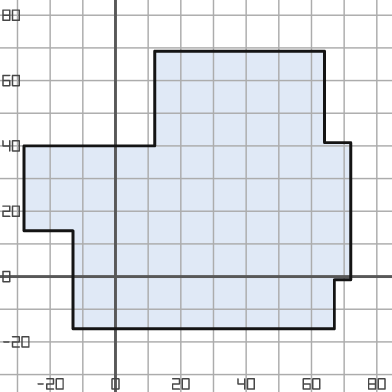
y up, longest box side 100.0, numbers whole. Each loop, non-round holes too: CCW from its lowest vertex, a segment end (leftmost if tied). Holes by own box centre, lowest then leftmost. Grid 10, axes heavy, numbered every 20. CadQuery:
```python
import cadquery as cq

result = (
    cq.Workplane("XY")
    .moveTo(-13.0, -16.0)
    .lineTo(67.0, -16.0)
    .lineTo(67.0, -1.0)
    .lineTo(72.0, -1.0)
    .lineTo(72.0, 41.0)
    .lineTo(64.0, 41.0)
    .lineTo(64.0, 69.0)
    .lineTo(12.0, 69.0)
    .lineTo(12.0, 40.0)
    .lineTo(-28.0, 40.0)
    .lineTo(-28.0, 14.0)
    .lineTo(-13.0, 14.0)
    .close()
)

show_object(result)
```